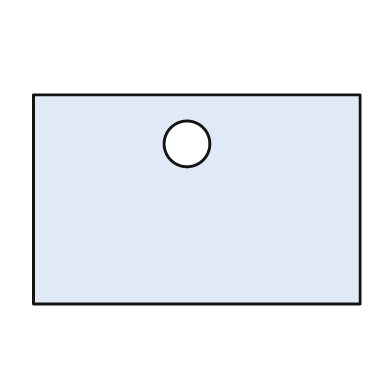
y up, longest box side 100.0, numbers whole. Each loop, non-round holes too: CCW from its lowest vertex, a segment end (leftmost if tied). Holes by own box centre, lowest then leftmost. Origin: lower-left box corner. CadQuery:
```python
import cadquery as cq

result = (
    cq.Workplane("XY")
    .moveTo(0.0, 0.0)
    .lineTo(100.0, 0.0)
    .lineTo(100.0, 64.0)
    .lineTo(0.0, 64.0)
    .close()
    .moveTo(47.0, 49.0)
    .circle(7.0)
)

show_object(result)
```